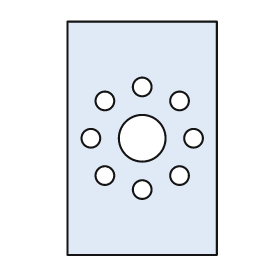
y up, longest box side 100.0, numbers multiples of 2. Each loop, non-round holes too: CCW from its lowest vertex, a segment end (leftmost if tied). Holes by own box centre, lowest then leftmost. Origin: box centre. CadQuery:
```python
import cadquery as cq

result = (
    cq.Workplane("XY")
    .moveTo(-32.0, -50.0)
    .lineTo(32.0, -50.0)
    .lineTo(32.0, 50.0)
    .lineTo(-32.0, 50.0)
    .close()
    .moveTo(0.0, -22.0)
    .circle(4.0)
    .moveTo(-16.0, -16.0)
    .circle(4.0)
    .moveTo(16.0, -16.0)
    .circle(4.0)
    .moveTo(-22.0, 0.0)
    .circle(4.0)
    .moveTo(0.0, 0.0)
    .circle(10.0)
    .moveTo(22.0, 0.0)
    .circle(4.0)
    .moveTo(-16.0, 16.0)
    .circle(4.0)
    .moveTo(16.0, 16.0)
    .circle(4.0)
    .moveTo(0.0, 22.0)
    .circle(4.0)
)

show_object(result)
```